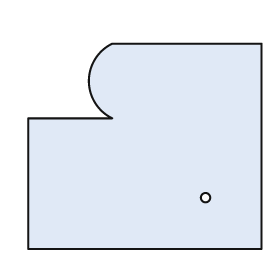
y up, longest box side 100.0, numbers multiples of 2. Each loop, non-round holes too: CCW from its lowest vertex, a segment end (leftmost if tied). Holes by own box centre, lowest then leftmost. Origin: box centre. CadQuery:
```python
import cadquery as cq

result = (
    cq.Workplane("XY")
    .moveTo(-50.0, -44.0)
    .lineTo(50.0, -44.0)
    .lineTo(50.0, 44.0)
    .lineTo(-14.0, 44.0)
    .threePointArc((-24.0, 28.0), (-14.0, 12.0))
    .lineTo(-50.0, 12.0)
    .close()
    .moveTo(26.0, -22.0)
    .circle(2.0)
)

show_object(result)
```